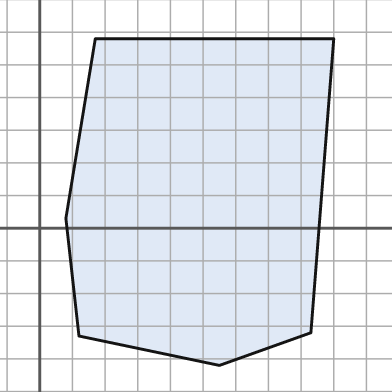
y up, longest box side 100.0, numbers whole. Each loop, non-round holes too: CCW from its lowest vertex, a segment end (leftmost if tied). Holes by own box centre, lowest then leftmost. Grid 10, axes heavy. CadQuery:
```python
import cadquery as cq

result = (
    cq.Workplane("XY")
    .moveTo(55.0, -42.0)
    .lineTo(83.0, -32.0)
    .lineTo(90.0, 58.0)
    .lineTo(17.0, 58.0)
    .lineTo(8.0, 3.0)
    .lineTo(12.0, -33.0)
    .close()
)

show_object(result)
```